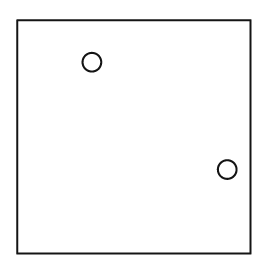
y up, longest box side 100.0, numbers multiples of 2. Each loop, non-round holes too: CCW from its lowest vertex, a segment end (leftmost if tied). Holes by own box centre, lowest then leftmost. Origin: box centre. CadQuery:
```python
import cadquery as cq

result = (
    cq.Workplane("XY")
    .moveTo(-50.0, -50.0)
    .lineTo(50.0, -50.0)
    .lineTo(50.0, 50.0)
    .lineTo(-50.0, 50.0)
    .close()
    .moveTo(40.0, -14.0)
    .circle(4.0)
    .moveTo(-18.0, 32.0)
    .circle(4.0)
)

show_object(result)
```